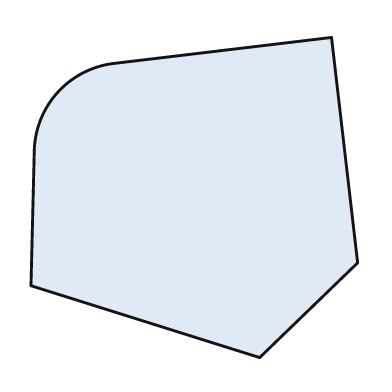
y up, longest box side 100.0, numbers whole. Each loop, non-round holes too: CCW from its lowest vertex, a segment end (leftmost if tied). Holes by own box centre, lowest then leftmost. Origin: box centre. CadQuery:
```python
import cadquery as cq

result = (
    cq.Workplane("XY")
    .moveTo(20.0, -49.0)
    .lineTo(50.0, -20.0)
    .lineTo(42.0, 49.0)
    .lineTo(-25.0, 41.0)
    .threePointArc((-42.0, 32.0), (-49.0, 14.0))
    .lineTo(-50.0, -27.0)
    .close()
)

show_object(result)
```